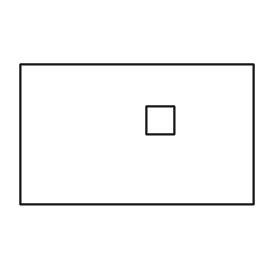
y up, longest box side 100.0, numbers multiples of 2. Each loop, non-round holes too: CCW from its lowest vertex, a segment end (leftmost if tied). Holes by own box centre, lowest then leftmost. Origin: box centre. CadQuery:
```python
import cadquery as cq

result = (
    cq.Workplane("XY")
    .moveTo(-50.0, -30.0)
    .lineTo(50.0, -30.0)
    .lineTo(50.0, 30.0)
    .lineTo(-50.0, 30.0)
    .close()
    .moveTo(4.0, 0.0)
    .lineTo(16.0, 0.0)
    .lineTo(16.0, 12.0)
    .lineTo(4.0, 12.0)
    .close()
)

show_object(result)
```